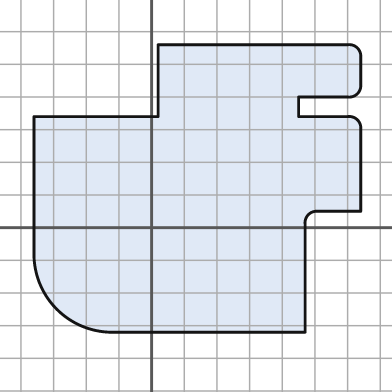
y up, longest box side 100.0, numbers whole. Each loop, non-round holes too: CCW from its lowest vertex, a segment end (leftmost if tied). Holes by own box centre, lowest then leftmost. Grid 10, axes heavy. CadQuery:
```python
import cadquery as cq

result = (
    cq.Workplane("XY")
    .moveTo(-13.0, -32.0)
    .lineTo(47.0, -32.0)
    .lineTo(47.0, 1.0)
    .threePointArc((48.0, 4.0), (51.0, 5.0))
    .lineTo(64.0, 5.0)
    .lineTo(64.0, 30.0)
    .threePointArc((63.0, 33.0), (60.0, 34.0))
    .lineTo(45.0, 34.0)
    .lineTo(45.0, 40.0)
    .lineTo(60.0, 40.0)
    .threePointArc((63.0, 41.0), (64.0, 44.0))
    .lineTo(64.0, 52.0)
    .threePointArc((63.0, 55.0), (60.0, 56.0))
    .lineTo(2.0, 56.0)
    .lineTo(2.0, 34.0)
    .lineTo(-36.0, 34.0)
    .lineTo(-36.0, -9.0)
    .threePointArc((-29.0, -25.0), (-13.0, -32.0))
    .close()
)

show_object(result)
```